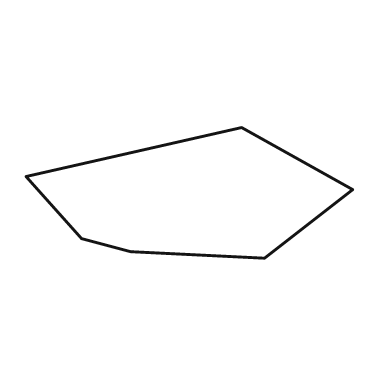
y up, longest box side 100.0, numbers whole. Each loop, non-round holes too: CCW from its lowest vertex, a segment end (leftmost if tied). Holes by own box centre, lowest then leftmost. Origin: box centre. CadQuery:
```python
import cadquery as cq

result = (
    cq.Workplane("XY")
    .moveTo(23.0, -20.0)
    .lineTo(50.0, 1.0)
    .lineTo(16.0, 20.0)
    .lineTo(-50.0, 5.0)
    .lineTo(-33.0, -14.0)
    .lineTo(-18.0, -18.0)
    .close()
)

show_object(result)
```